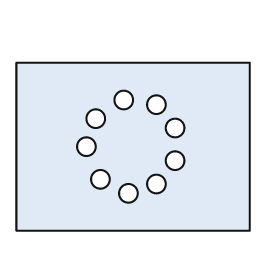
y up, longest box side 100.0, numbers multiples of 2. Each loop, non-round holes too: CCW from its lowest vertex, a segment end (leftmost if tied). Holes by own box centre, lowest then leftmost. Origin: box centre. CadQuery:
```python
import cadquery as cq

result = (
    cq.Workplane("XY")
    .moveTo(-50.0, -36.0)
    .lineTo(50.0, -36.0)
    .lineTo(50.0, 36.0)
    .lineTo(-50.0, 36.0)
    .close()
    .moveTo(-2.0, -20.0)
    .circle(4.0)
    .moveTo(10.0, -16.0)
    .circle(4.0)
    .moveTo(-14.0, -14.0)
    .circle(4.0)
    .moveTo(18.0, -6.0)
    .circle(4.0)
    .moveTo(-20.0, 0.0)
    .circle(4.0)
    .moveTo(18.0, 8.0)
    .circle(4.0)
    .moveTo(-16.0, 12.0)
    .circle(4.0)
    .moveTo(10.0, 18.0)
    .circle(4.0)
    .moveTo(-4.0, 20.0)
    .circle(4.0)
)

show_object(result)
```